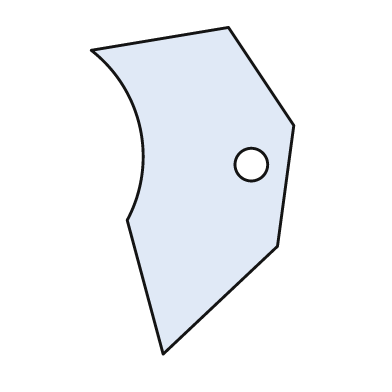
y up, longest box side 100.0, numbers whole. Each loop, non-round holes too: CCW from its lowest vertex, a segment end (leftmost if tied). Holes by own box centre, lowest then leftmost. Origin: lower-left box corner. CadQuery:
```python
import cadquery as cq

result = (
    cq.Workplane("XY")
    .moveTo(22.0, 0.0)
    .lineTo(57.0, 33.0)
    .lineTo(62.0, 70.0)
    .lineTo(42.0, 100.0)
    .lineTo(0.0, 93.0)
    .threePointArc((15.0, 69.0), (11.0, 41.0))
    .close()
    .moveTo(49.0, 58.0)
    .circle(5.0)
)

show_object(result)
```